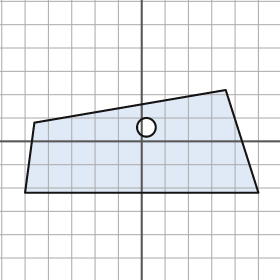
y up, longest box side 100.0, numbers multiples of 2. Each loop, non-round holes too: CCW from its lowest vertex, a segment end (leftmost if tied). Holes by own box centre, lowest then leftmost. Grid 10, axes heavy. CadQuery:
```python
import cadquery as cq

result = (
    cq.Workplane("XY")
    .moveTo(-50.0, -22.0)
    .lineTo(50.0, -22.0)
    .lineTo(36.0, 22.0)
    .lineTo(-46.0, 8.0)
    .close()
    .moveTo(2.0, 6.0)
    .circle(4.0)
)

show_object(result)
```